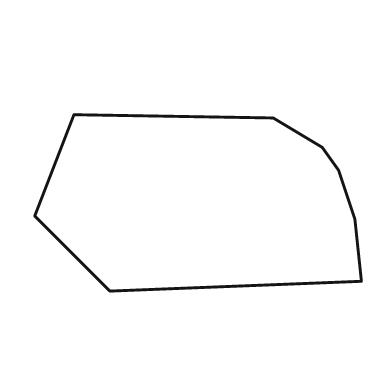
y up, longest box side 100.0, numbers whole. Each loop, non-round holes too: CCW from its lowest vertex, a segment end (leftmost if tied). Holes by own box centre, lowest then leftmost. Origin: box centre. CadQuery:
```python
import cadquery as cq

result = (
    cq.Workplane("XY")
    .moveTo(-27.0, -27.0)
    .lineTo(50.0, -24.0)
    .lineTo(48.0, -5.0)
    .lineTo(43.0, 10.0)
    .lineTo(38.0, 17.0)
    .lineTo(23.0, 26.0)
    .lineTo(-38.0, 27.0)
    .lineTo(-50.0, -4.0)
    .close()
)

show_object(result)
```